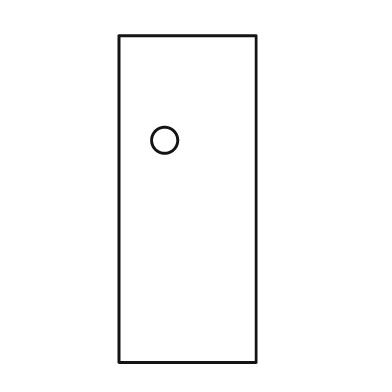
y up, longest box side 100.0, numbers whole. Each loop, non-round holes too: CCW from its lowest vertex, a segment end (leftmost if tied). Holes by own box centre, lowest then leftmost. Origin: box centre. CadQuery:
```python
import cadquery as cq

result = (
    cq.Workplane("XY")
    .moveTo(-21.0, -50.0)
    .lineTo(21.0, -50.0)
    .lineTo(21.0, 50.0)
    .lineTo(-21.0, 50.0)
    .close()
    .moveTo(-7.0, 18.0)
    .circle(4.0)
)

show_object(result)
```